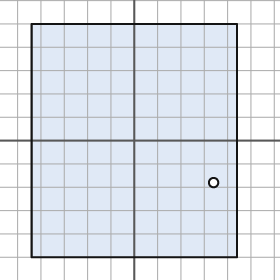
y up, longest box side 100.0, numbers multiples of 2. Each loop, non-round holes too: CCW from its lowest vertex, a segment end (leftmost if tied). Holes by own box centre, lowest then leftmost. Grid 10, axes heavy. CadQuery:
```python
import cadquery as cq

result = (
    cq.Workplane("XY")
    .moveTo(-44.0, -50.0)
    .lineTo(44.0, -50.0)
    .lineTo(44.0, 50.0)
    .lineTo(-44.0, 50.0)
    .close()
    .moveTo(34.0, -18.0)
    .circle(2.0)
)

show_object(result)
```